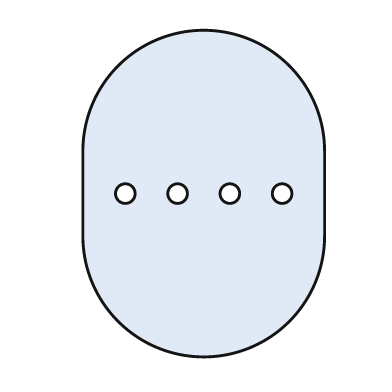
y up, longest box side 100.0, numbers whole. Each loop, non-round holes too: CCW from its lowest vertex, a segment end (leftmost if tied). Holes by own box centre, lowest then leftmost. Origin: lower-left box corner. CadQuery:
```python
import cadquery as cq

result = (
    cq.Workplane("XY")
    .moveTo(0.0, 37.0)
    .threePointArc((37.0, 0.0), (74.0, 37.0))
    .lineTo(74.0, 63.0)
    .threePointArc((37.0, 100.0), (0.0, 63.0))
    .close()
    .moveTo(13.0, 50.0)
    .circle(3.0)
    .moveTo(29.0, 50.0)
    .circle(3.0)
    .moveTo(45.0, 50.0)
    .circle(3.0)
    .moveTo(61.0, 50.0)
    .circle(3.0)
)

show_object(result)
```